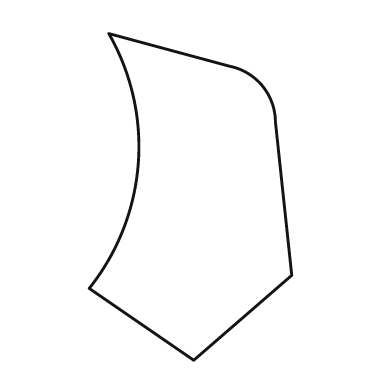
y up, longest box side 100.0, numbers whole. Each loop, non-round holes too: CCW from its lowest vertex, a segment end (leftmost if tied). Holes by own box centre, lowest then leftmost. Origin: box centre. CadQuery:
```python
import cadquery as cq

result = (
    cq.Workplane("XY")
    .moveTo(1.0, -50.0)
    .lineTo(31.0, -24.0)
    .lineTo(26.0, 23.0)
    .threePointArc((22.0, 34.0), (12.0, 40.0))
    .lineTo(-25.0, 50.0)
    .threePointArc((-16.0, 10.0), (-31.0, -28.0))
    .close()
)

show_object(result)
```